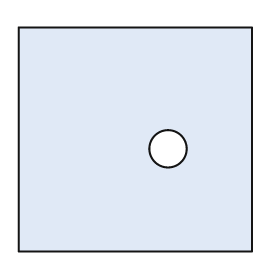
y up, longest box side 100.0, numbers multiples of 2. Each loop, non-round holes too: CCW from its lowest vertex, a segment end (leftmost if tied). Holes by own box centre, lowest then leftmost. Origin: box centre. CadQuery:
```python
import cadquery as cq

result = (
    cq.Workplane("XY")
    .moveTo(-50.0, -48.0)
    .lineTo(50.0, -48.0)
    .lineTo(50.0, 48.0)
    .lineTo(-50.0, 48.0)
    .close()
    .moveTo(14.0, -4.0)
    .circle(8.0)
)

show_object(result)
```